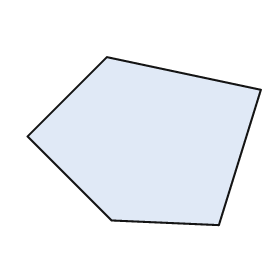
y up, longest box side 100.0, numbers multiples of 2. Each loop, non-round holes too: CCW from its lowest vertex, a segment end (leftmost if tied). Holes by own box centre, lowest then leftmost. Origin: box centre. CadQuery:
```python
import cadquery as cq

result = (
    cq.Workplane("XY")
    .moveTo(32.0, -36.0)
    .lineTo(50.0, 22.0)
    .lineTo(-16.0, 36.0)
    .lineTo(-50.0, 2.0)
    .lineTo(-14.0, -34.0)
    .close()
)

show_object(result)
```